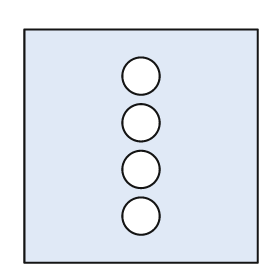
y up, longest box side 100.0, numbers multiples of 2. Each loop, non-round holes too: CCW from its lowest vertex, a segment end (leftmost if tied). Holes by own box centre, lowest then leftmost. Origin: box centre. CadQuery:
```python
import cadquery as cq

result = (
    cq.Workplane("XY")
    .moveTo(-50.0, -50.0)
    .lineTo(50.0, -50.0)
    .lineTo(50.0, 50.0)
    .lineTo(-50.0, 50.0)
    .close()
    .moveTo(0.0, -30.0)
    .circle(8.0)
    .moveTo(0.0, -10.0)
    .circle(8.0)
    .moveTo(0.0, 10.0)
    .circle(8.0)
    .moveTo(0.0, 30.0)
    .circle(8.0)
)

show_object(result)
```